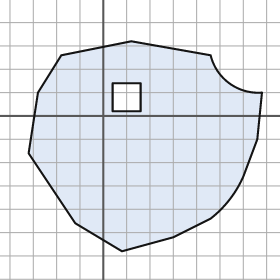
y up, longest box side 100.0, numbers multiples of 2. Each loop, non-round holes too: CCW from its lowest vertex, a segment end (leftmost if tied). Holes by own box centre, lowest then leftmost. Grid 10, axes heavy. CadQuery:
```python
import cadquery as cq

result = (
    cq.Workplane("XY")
    .moveTo(8.0, -58.0)
    .lineTo(30.0, -52.0)
    .lineTo(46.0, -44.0)
    .threePointArc((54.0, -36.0), (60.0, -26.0))
    .lineTo(66.0, -10.0)
    .lineTo(68.0, 10.0)
    .threePointArc((54.0, 14.0), (46.0, 26.0))
    .lineTo(12.0, 32.0)
    .lineTo(-18.0, 26.0)
    .lineTo(-28.0, 10.0)
    .lineTo(-32.0, -16.0)
    .lineTo(-12.0, -46.0)
    .close()
    .moveTo(4.0, 2.0)
    .lineTo(16.0, 2.0)
    .lineTo(16.0, 14.0)
    .lineTo(4.0, 14.0)
    .close()
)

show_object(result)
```